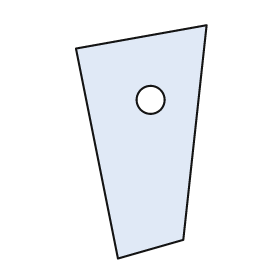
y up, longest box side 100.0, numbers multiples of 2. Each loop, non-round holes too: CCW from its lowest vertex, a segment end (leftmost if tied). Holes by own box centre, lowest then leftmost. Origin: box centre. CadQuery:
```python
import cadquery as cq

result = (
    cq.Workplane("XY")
    .moveTo(-10.0, -50.0)
    .lineTo(18.0, -42.0)
    .lineTo(28.0, 50.0)
    .lineTo(-28.0, 40.0)
    .close()
    .moveTo(4.0, 18.0)
    .circle(6.0)
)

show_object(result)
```